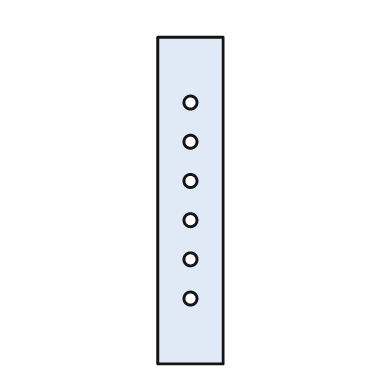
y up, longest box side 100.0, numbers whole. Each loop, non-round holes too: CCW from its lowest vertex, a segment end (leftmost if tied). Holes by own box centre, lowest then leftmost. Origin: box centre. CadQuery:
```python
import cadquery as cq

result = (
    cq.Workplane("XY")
    .moveTo(-10.0, -50.0)
    .lineTo(10.0, -50.0)
    .lineTo(10.0, 50.0)
    .lineTo(-10.0, 50.0)
    .close()
    .moveTo(0.0, -30.0)
    .circle(2.0)
    .moveTo(0.0, -18.0)
    .circle(2.0)
    .moveTo(0.0, -6.0)
    .circle(2.0)
    .moveTo(0.0, 6.0)
    .circle(2.0)
    .moveTo(0.0, 18.0)
    .circle(2.0)
    .moveTo(0.0, 30.0)
    .circle(2.0)
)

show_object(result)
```